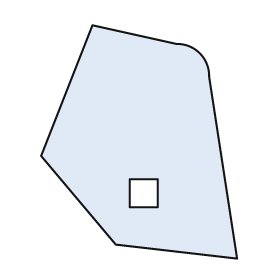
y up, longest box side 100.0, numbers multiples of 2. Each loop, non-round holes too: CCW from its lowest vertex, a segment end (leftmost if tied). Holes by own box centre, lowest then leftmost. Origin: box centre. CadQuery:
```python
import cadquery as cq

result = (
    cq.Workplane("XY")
    .moveTo(42.0, -50.0)
    .lineTo(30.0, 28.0)
    .threePointArc((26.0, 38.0), (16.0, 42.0))
    .lineTo(-20.0, 50.0)
    .lineTo(-42.0, -6.0)
    .lineTo(-10.0, -44.0)
    .close()
    .moveTo(-4.0, -28.0)
    .lineTo(8.0, -28.0)
    .lineTo(8.0, -16.0)
    .lineTo(-4.0, -16.0)
    .close()
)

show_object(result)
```